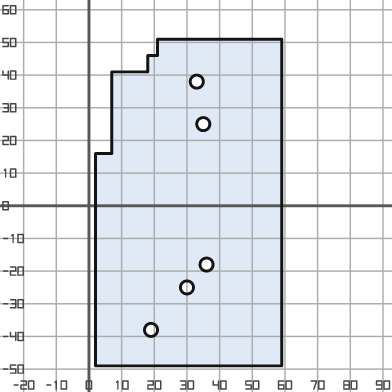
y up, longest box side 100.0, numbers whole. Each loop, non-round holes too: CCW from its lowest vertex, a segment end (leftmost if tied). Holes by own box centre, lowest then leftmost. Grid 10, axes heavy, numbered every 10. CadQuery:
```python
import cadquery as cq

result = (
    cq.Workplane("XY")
    .moveTo(2.0, -49.0)
    .lineTo(59.0, -49.0)
    .lineTo(59.0, 51.0)
    .lineTo(21.0, 51.0)
    .lineTo(21.0, 46.0)
    .lineTo(18.0, 46.0)
    .lineTo(18.0, 41.0)
    .lineTo(7.0, 41.0)
    .lineTo(7.0, 16.0)
    .lineTo(2.0, 16.0)
    .close()
    .moveTo(19.0, -38.0)
    .circle(2.0)
    .moveTo(30.0, -25.0)
    .circle(2.0)
    .moveTo(36.0, -18.0)
    .circle(2.0)
    .moveTo(35.0, 25.0)
    .circle(2.0)
    .moveTo(33.0, 38.0)
    .circle(2.0)
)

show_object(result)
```